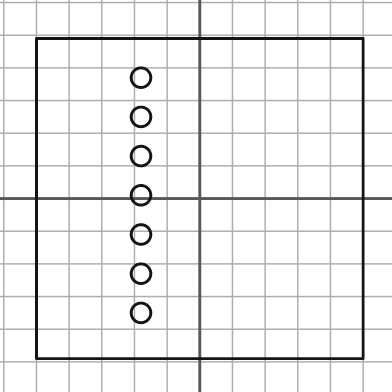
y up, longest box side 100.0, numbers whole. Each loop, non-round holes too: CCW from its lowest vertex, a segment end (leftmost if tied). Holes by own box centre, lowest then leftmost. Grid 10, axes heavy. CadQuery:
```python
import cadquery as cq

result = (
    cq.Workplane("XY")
    .moveTo(-50.0, -49.0)
    .lineTo(50.0, -49.0)
    .lineTo(50.0, 49.0)
    .lineTo(-50.0, 49.0)
    .close()
    .moveTo(-18.0, -35.0)
    .circle(3.0)
    .moveTo(-18.0, -23.0)
    .circle(3.0)
    .moveTo(-18.0, -11.0)
    .circle(3.0)
    .moveTo(-18.0, 1.0)
    .circle(3.0)
    .moveTo(-18.0, 13.0)
    .circle(3.0)
    .moveTo(-18.0, 25.0)
    .circle(3.0)
    .moveTo(-18.0, 37.0)
    .circle(3.0)
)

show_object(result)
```